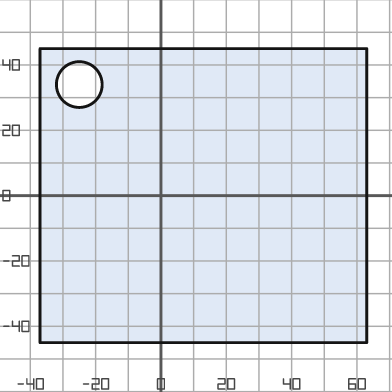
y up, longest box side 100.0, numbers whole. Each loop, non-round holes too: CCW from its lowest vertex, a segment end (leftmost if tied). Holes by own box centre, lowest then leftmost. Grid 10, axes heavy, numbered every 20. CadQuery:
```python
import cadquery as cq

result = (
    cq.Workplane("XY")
    .moveTo(-37.0, -45.0)
    .lineTo(63.0, -45.0)
    .lineTo(63.0, 45.0)
    .lineTo(-37.0, 45.0)
    .close()
    .moveTo(-25.0, 34.0)
    .circle(7.0)
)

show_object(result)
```